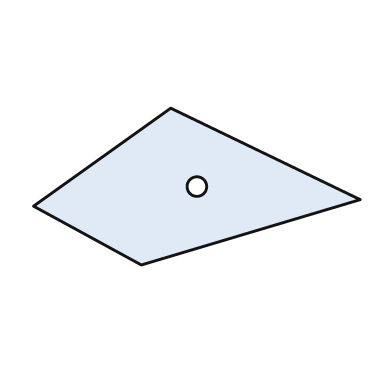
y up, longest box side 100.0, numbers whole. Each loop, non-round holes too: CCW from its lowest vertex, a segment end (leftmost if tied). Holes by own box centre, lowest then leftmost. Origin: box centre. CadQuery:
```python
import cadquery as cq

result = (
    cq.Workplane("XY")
    .moveTo(-17.0, -24.0)
    .lineTo(50.0, -4.0)
    .lineTo(-8.0, 24.0)
    .lineTo(-50.0, -6.0)
    .close()
    .moveTo(0.0, 0.0)
    .circle(3.0)
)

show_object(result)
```